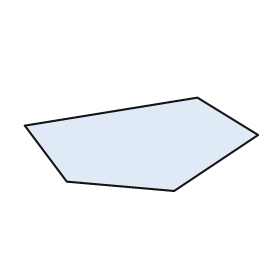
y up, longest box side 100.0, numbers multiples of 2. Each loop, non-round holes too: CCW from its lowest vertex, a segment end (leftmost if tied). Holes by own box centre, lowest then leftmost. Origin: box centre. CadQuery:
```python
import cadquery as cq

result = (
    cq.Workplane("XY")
    .moveTo(14.0, -20.0)
    .lineTo(50.0, 4.0)
    .lineTo(24.0, 20.0)
    .lineTo(-50.0, 8.0)
    .lineTo(-32.0, -16.0)
    .close()
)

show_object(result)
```